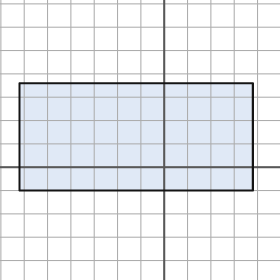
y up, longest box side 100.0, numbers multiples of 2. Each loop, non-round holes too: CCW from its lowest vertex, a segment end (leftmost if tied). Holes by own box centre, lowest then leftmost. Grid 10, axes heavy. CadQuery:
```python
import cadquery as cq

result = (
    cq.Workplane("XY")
    .moveTo(-62.0, -10.0)
    .lineTo(38.0, -10.0)
    .lineTo(38.0, 36.0)
    .lineTo(-62.0, 36.0)
    .close()
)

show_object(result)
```